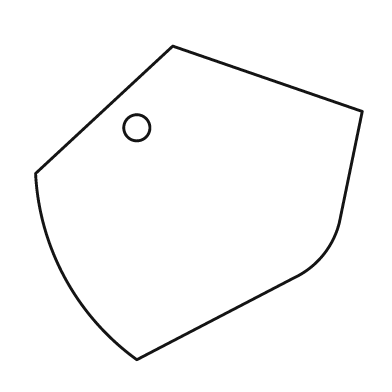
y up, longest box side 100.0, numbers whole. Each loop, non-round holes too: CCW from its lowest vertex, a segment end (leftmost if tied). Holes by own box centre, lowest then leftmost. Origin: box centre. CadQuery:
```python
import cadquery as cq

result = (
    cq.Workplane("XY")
    .moveTo(-19.0, -48.0)
    .lineTo(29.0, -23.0)
    .threePointArc((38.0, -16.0), (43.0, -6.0))
    .lineTo(50.0, 28.0)
    .lineTo(-8.0, 48.0)
    .lineTo(-50.0, 9.0)
    .threePointArc((-41.0, -23.0), (-19.0, -48.0))
    .close()
    .moveTo(-19.0, 23.0)
    .circle(4.0)
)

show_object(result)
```